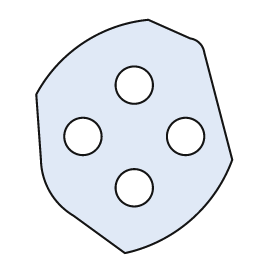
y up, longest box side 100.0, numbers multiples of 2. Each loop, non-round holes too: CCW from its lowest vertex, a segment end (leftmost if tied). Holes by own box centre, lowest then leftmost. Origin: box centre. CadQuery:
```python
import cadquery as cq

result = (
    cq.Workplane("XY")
    .moveTo(-4.0, -50.0)
    .threePointArc((24.0, -36.0), (42.0, -10.0))
    .lineTo(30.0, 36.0)
    .threePointArc((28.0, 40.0), (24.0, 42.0))
    .lineTo(6.0, 50.0)
    .threePointArc((-22.0, 40.0), (-42.0, 18.0))
    .lineTo(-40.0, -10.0)
    .threePointArc((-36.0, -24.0), (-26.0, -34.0))
    .close()
    .moveTo(0.0, -22.0)
    .circle(8.0)
    .moveTo(-22.0, 0.0)
    .circle(8.0)
    .moveTo(22.0, 0.0)
    .circle(8.0)
    .moveTo(0.0, 22.0)
    .circle(8.0)
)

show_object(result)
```